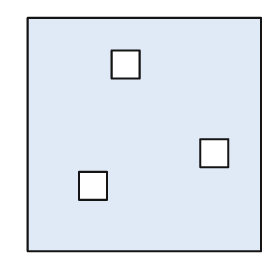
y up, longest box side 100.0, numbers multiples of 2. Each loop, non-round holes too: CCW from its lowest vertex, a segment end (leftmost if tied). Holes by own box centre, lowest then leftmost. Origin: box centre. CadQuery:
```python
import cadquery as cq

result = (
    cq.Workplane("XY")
    .moveTo(-50.0, -50.0)
    .lineTo(50.0, -50.0)
    .lineTo(50.0, 50.0)
    .lineTo(-50.0, 50.0)
    .close()
    .moveTo(-28.0, -28.0)
    .lineTo(-16.0, -28.0)
    .lineTo(-16.0, -16.0)
    .lineTo(-28.0, -16.0)
    .close()
    .moveTo(24.0, -14.0)
    .lineTo(36.0, -14.0)
    .lineTo(36.0, -2.0)
    .lineTo(24.0, -2.0)
    .close()
    .moveTo(-14.0, 24.0)
    .lineTo(-2.0, 24.0)
    .lineTo(-2.0, 36.0)
    .lineTo(-14.0, 36.0)
    .close()
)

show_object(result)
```